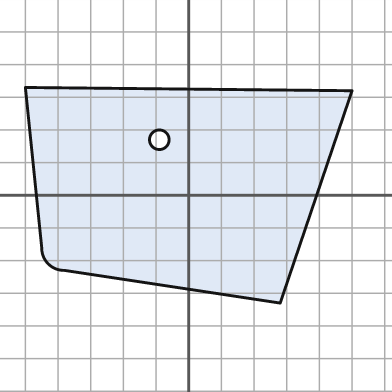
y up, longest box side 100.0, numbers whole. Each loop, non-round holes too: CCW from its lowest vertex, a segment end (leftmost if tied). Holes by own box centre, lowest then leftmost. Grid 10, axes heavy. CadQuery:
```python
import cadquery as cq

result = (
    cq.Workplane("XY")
    .moveTo(28.0, -33.0)
    .lineTo(50.0, 32.0)
    .lineTo(-50.0, 33.0)
    .lineTo(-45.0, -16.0)
    .threePointArc((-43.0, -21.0), (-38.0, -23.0))
    .close()
    .moveTo(-9.0, 17.0)
    .circle(3.0)
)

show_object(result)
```